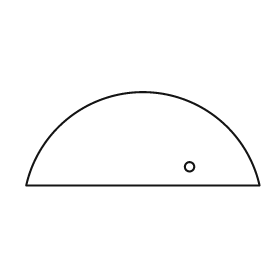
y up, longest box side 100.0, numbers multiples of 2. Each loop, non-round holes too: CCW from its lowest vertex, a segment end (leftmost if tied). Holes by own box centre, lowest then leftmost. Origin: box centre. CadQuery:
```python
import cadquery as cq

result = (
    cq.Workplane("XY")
    .moveTo(-50.0, -20.0)
    .lineTo(50.0, -20.0)
    .threePointArc((0.0, 20.0), (-50.0, -20.0))
    .close()
    .moveTo(20.0, -12.0)
    .circle(2.0)
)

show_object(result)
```